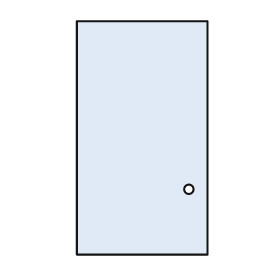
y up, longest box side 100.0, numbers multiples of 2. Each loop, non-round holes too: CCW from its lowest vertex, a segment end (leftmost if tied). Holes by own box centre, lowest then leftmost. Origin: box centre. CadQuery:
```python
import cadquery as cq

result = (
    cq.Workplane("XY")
    .moveTo(-28.0, -50.0)
    .lineTo(28.0, -50.0)
    .lineTo(28.0, 50.0)
    .lineTo(-28.0, 50.0)
    .close()
    .moveTo(20.0, -22.0)
    .circle(2.0)
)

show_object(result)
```